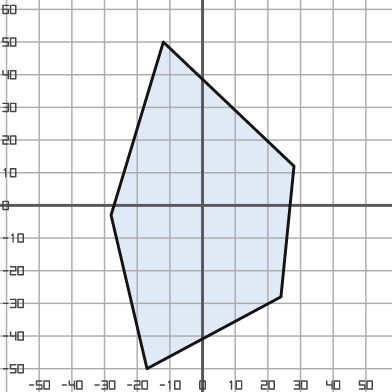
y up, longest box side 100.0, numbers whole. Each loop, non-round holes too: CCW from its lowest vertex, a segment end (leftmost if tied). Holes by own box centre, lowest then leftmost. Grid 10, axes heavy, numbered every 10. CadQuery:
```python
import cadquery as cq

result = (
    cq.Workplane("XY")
    .moveTo(-17.0, -50.0)
    .lineTo(24.0, -28.0)
    .lineTo(28.0, 12.0)
    .lineTo(-12.0, 50.0)
    .lineTo(-28.0, -3.0)
    .close()
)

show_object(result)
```